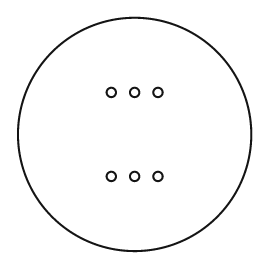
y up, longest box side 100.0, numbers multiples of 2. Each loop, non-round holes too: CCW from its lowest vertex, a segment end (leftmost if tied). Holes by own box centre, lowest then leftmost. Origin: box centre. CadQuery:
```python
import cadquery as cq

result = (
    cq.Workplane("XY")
    .moveTo(0.0, 0.0)
    .circle(50.0)
    .moveTo(-10.0, -18.0)
    .circle(2.0)
    .moveTo(0.0, -18.0)
    .circle(2.0)
    .moveTo(10.0, -18.0)
    .circle(2.0)
    .moveTo(-10.0, 18.0)
    .circle(2.0)
    .moveTo(0.0, 18.0)
    .circle(2.0)
    .moveTo(10.0, 18.0)
    .circle(2.0)
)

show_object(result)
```